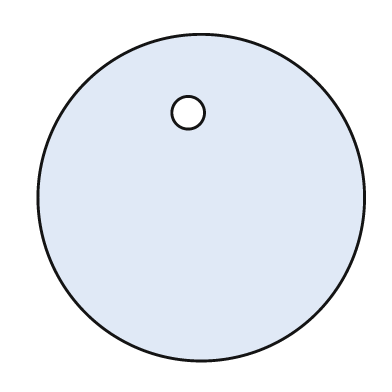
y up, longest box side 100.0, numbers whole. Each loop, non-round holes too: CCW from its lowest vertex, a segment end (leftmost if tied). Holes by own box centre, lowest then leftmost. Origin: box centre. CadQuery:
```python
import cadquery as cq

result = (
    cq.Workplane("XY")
    .moveTo(0.0, 0.0)
    .circle(50.0)
    .moveTo(-4.0, 26.0)
    .circle(5.0)
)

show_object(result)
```